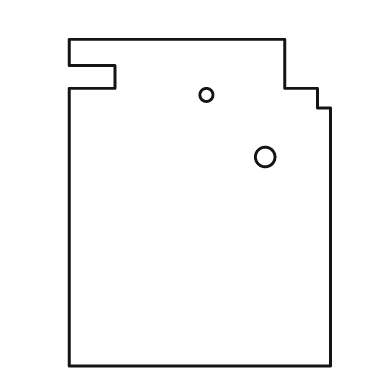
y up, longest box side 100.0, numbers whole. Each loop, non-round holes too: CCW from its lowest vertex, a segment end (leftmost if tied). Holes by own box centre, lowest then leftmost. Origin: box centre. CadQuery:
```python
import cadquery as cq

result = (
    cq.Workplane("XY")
    .moveTo(-40.0, -50.0)
    .lineTo(40.0, -50.0)
    .lineTo(40.0, 29.0)
    .lineTo(36.0, 29.0)
    .lineTo(36.0, 35.0)
    .lineTo(26.0, 35.0)
    .lineTo(26.0, 50.0)
    .lineTo(-40.0, 50.0)
    .lineTo(-40.0, 42.0)
    .lineTo(-26.0, 42.0)
    .lineTo(-26.0, 35.0)
    .lineTo(-40.0, 35.0)
    .close()
    .moveTo(20.0, 14.0)
    .circle(3.0)
    .moveTo(2.0, 33.0)
    .circle(2.0)
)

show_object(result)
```